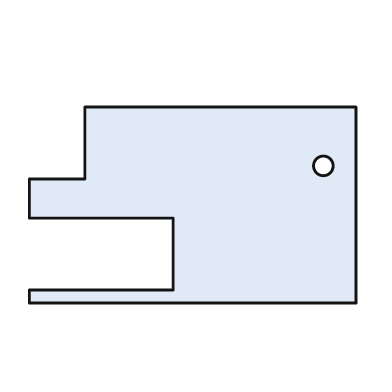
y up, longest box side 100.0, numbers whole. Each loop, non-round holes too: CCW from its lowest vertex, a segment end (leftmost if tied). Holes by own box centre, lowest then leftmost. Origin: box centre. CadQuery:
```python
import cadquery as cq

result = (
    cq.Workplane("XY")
    .moveTo(-50.0, -30.0)
    .lineTo(50.0, -30.0)
    .lineTo(50.0, 30.0)
    .lineTo(-33.0, 30.0)
    .lineTo(-33.0, 8.0)
    .lineTo(-50.0, 8.0)
    .lineTo(-50.0, -4.0)
    .lineTo(-6.0, -4.0)
    .lineTo(-6.0, -26.0)
    .lineTo(-50.0, -26.0)
    .close()
    .moveTo(40.0, 12.0)
    .circle(3.0)
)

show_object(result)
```